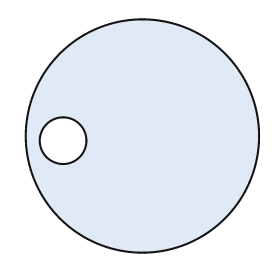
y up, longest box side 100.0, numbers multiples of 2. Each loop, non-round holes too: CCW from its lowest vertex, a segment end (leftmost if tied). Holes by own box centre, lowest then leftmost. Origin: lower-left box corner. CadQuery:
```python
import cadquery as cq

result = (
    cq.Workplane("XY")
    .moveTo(50.0, 50.0)
    .circle(50.0)
    .moveTo(16.0, 48.0)
    .circle(10.0)
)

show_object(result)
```